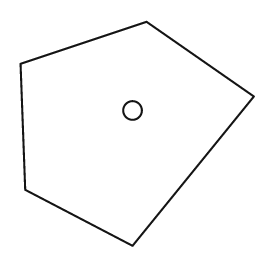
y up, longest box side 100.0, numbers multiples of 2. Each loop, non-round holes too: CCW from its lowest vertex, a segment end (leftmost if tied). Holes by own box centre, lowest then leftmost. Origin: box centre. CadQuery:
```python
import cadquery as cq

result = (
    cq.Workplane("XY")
    .moveTo(-2.0, -48.0)
    .lineTo(50.0, 16.0)
    .lineTo(4.0, 48.0)
    .lineTo(-50.0, 30.0)
    .lineTo(-48.0, -24.0)
    .close()
    .moveTo(-2.0, 10.0)
    .circle(4.0)
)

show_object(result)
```